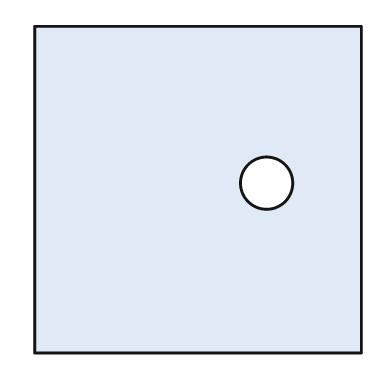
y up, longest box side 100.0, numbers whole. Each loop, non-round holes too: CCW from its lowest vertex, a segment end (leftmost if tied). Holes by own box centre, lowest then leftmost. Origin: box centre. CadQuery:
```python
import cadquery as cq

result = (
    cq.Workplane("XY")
    .moveTo(-50.0, -50.0)
    .lineTo(50.0, -50.0)
    .lineTo(50.0, 50.0)
    .lineTo(-50.0, 50.0)
    .close()
    .moveTo(21.0, 2.0)
    .circle(8.0)
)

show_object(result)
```